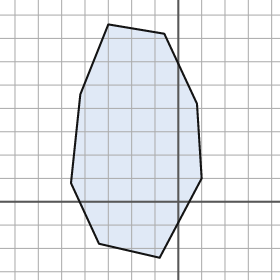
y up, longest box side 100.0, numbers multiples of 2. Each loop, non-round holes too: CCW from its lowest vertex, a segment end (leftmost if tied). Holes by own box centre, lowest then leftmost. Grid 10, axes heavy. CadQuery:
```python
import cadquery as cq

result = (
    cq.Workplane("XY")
    .moveTo(-8.0, -24.0)
    .lineTo(10.0, 10.0)
    .lineTo(8.0, 42.0)
    .lineTo(-6.0, 72.0)
    .lineTo(-30.0, 76.0)
    .lineTo(-42.0, 46.0)
    .lineTo(-46.0, 8.0)
    .lineTo(-34.0, -18.0)
    .close()
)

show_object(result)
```